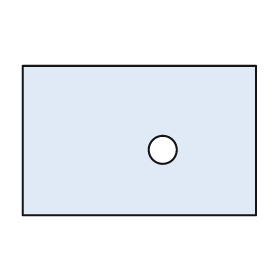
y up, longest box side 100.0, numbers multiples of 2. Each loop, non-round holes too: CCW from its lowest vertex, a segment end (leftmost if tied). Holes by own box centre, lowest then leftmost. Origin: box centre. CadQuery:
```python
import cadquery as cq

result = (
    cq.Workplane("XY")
    .moveTo(-50.0, -32.0)
    .lineTo(50.0, -32.0)
    .lineTo(50.0, 32.0)
    .lineTo(-50.0, 32.0)
    .close()
    .moveTo(10.0, -4.0)
    .circle(6.0)
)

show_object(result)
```